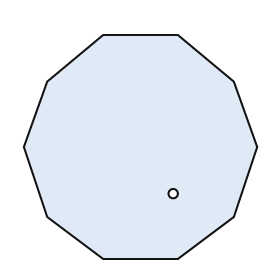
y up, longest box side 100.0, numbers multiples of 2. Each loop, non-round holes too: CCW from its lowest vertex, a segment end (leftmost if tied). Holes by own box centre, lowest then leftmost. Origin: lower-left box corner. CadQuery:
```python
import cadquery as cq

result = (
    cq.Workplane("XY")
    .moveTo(34.0, 0.0)
    .lineTo(66.0, 0.0)
    .lineTo(90.0, 18.0)
    .lineTo(100.0, 48.0)
    .lineTo(90.0, 76.0)
    .lineTo(66.0, 96.0)
    .lineTo(34.0, 96.0)
    .lineTo(10.0, 76.0)
    .lineTo(0.0, 48.0)
    .lineTo(10.0, 18.0)
    .close()
    .moveTo(64.0, 28.0)
    .circle(2.0)
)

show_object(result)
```